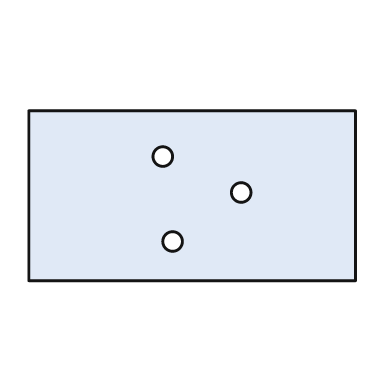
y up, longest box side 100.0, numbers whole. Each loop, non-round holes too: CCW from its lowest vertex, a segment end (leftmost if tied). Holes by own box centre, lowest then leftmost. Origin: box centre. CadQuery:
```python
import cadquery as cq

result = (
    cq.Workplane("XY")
    .moveTo(-50.0, -26.0)
    .lineTo(50.0, -26.0)
    .lineTo(50.0, 26.0)
    .lineTo(-50.0, 26.0)
    .close()
    .moveTo(-6.0, -14.0)
    .circle(3.0)
    .moveTo(15.0, 1.0)
    .circle(3.0)
    .moveTo(-9.0, 12.0)
    .circle(3.0)
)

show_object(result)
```